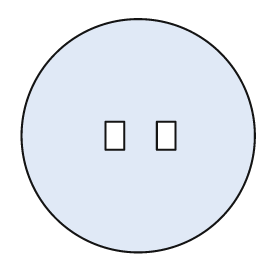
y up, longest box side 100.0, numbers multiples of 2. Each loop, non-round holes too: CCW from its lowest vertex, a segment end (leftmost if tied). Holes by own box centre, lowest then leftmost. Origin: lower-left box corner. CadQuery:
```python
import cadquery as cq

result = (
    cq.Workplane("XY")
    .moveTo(50.0, 50.0)
    .circle(50.0)
    .moveTo(36.0, 44.0)
    .lineTo(44.0, 44.0)
    .lineTo(44.0, 56.0)
    .lineTo(36.0, 56.0)
    .close()
    .moveTo(58.0, 44.0)
    .lineTo(66.0, 44.0)
    .lineTo(66.0, 56.0)
    .lineTo(58.0, 56.0)
    .close()
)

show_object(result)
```